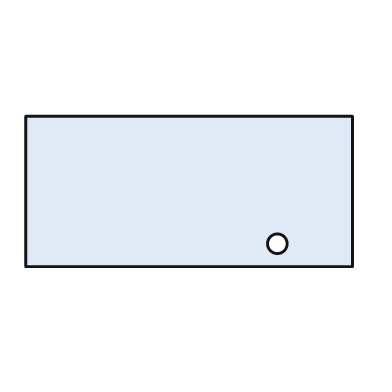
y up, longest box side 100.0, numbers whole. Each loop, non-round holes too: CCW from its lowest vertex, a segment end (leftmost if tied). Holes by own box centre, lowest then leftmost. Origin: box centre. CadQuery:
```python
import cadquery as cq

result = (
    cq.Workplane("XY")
    .moveTo(-50.0, -23.0)
    .lineTo(50.0, -23.0)
    .lineTo(50.0, 23.0)
    .lineTo(-50.0, 23.0)
    .close()
    .moveTo(27.0, -16.0)
    .circle(3.0)
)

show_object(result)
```